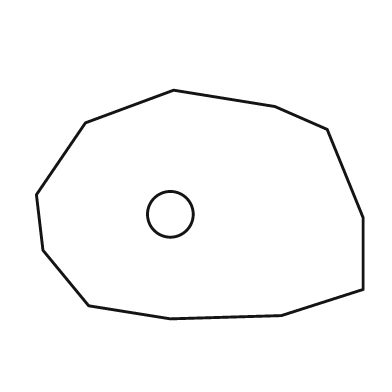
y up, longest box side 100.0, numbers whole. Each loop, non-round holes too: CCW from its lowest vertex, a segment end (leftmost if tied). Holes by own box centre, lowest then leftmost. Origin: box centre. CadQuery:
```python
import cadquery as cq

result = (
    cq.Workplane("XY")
    .moveTo(-9.0, -35.0)
    .lineTo(25.0, -34.0)
    .lineTo(50.0, -26.0)
    .lineTo(50.0, -4.0)
    .lineTo(39.0, 23.0)
    .lineTo(23.0, 30.0)
    .lineTo(-8.0, 35.0)
    .lineTo(-35.0, 25.0)
    .lineTo(-50.0, 3.0)
    .lineTo(-48.0, -14.0)
    .lineTo(-34.0, -31.0)
    .close()
    .moveTo(-9.0, -3.0)
    .circle(7.0)
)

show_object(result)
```